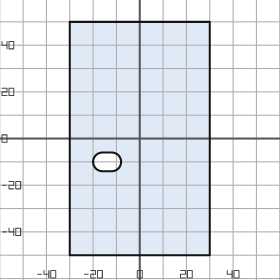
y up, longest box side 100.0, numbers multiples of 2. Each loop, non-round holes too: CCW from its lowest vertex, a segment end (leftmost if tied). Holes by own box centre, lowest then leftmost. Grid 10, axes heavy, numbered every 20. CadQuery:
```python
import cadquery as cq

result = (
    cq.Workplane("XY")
    .moveTo(-30.0, -50.0)
    .lineTo(30.0, -50.0)
    .lineTo(30.0, 50.0)
    .lineTo(-30.0, 50.0)
    .close()
    .moveTo(-16.0, -14.0)
    .lineTo(-12.0, -14.0)
    .threePointArc((-8.0, -10.0), (-12.0, -6.0))
    .lineTo(-16.0, -6.0)
    .threePointArc((-20.0, -10.0), (-16.0, -14.0))
    .close()
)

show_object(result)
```